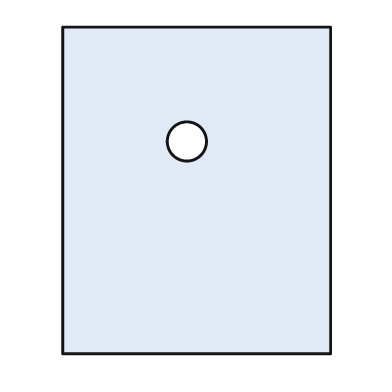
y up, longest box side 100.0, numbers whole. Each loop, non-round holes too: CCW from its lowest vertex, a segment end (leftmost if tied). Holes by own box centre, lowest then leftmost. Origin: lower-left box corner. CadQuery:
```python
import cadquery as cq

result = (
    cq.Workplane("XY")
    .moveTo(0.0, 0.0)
    .lineTo(82.0, 0.0)
    .lineTo(82.0, 100.0)
    .lineTo(0.0, 100.0)
    .close()
    .moveTo(38.0, 65.0)
    .circle(6.0)
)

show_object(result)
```